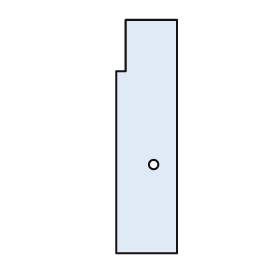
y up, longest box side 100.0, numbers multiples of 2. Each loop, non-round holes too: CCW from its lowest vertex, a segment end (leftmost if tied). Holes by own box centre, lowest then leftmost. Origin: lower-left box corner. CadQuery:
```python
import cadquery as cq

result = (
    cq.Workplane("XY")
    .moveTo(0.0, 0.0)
    .lineTo(26.0, 0.0)
    .lineTo(26.0, 100.0)
    .lineTo(4.0, 100.0)
    .lineTo(4.0, 78.0)
    .lineTo(0.0, 78.0)
    .close()
    .moveTo(16.0, 38.0)
    .circle(2.0)
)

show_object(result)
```